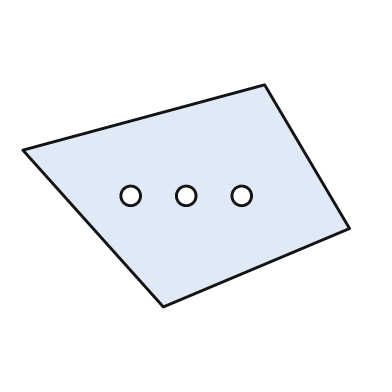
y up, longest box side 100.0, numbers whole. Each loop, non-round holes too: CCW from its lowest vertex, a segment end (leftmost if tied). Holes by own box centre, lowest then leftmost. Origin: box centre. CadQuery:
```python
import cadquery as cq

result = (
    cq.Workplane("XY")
    .moveTo(-7.0, -34.0)
    .lineTo(50.0, -10.0)
    .lineTo(24.0, 34.0)
    .lineTo(-50.0, 14.0)
    .close()
    .moveTo(-17.0, 0.0)
    .circle(3.0)
    .moveTo(0.0, 0.0)
    .circle(3.0)
    .moveTo(17.0, 0.0)
    .circle(3.0)
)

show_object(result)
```